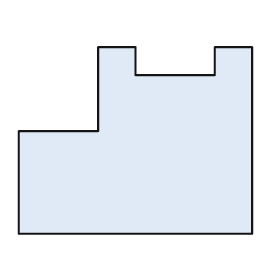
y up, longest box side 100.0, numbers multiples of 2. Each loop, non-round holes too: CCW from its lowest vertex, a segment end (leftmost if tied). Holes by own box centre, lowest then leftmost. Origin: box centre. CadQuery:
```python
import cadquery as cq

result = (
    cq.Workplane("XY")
    .moveTo(-50.0, -40.0)
    .lineTo(50.0, -40.0)
    .lineTo(50.0, 40.0)
    .lineTo(34.0, 40.0)
    .lineTo(34.0, 28.0)
    .lineTo(0.0, 28.0)
    .lineTo(0.0, 40.0)
    .lineTo(-16.0, 40.0)
    .lineTo(-16.0, 4.0)
    .lineTo(-50.0, 4.0)
    .close()
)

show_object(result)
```